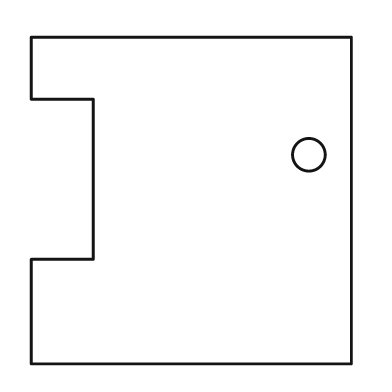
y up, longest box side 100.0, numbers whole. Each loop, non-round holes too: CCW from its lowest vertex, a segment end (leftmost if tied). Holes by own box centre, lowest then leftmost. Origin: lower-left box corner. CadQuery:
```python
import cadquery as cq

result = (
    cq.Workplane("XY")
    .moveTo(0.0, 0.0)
    .lineTo(98.0, 0.0)
    .lineTo(98.0, 100.0)
    .lineTo(0.0, 100.0)
    .lineTo(0.0, 81.0)
    .lineTo(19.0, 81.0)
    .lineTo(19.0, 32.0)
    .lineTo(0.0, 32.0)
    .close()
    .moveTo(85.0, 64.0)
    .circle(5.0)
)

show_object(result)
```